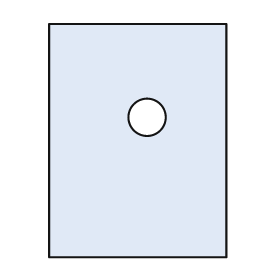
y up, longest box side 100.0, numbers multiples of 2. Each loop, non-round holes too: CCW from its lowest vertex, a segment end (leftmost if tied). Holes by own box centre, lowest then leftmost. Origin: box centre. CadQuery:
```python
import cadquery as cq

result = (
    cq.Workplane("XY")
    .moveTo(-38.0, -50.0)
    .lineTo(38.0, -50.0)
    .lineTo(38.0, 50.0)
    .lineTo(-38.0, 50.0)
    .close()
    .moveTo(4.0, 10.0)
    .circle(8.0)
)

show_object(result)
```